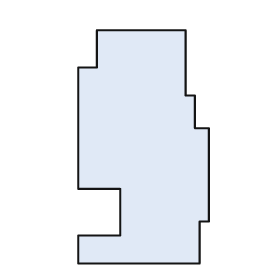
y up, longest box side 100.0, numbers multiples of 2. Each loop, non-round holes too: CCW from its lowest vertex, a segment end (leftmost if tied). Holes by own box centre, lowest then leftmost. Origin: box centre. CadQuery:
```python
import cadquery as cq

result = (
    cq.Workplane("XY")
    .moveTo(-28.0, -50.0)
    .lineTo(24.0, -50.0)
    .lineTo(24.0, -32.0)
    .lineTo(28.0, -32.0)
    .lineTo(28.0, 8.0)
    .lineTo(22.0, 8.0)
    .lineTo(22.0, 22.0)
    .lineTo(18.0, 22.0)
    .lineTo(18.0, 50.0)
    .lineTo(-20.0, 50.0)
    .lineTo(-20.0, 34.0)
    .lineTo(-28.0, 34.0)
    .lineTo(-28.0, -18.0)
    .lineTo(-10.0, -18.0)
    .lineTo(-10.0, -38.0)
    .lineTo(-28.0, -38.0)
    .close()
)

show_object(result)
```